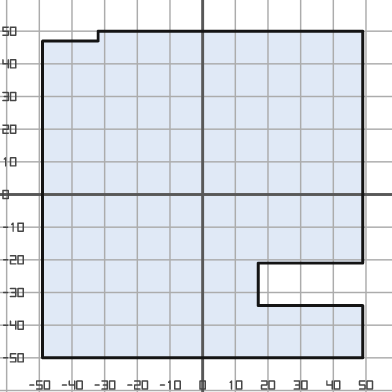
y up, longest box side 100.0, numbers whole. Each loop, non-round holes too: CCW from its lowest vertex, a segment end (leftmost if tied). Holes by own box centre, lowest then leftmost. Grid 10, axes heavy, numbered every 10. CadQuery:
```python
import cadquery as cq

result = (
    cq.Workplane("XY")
    .moveTo(-49.0, -50.0)
    .lineTo(49.0, -50.0)
    .lineTo(49.0, -34.0)
    .lineTo(17.0, -34.0)
    .lineTo(17.0, -21.0)
    .lineTo(49.0, -21.0)
    .lineTo(49.0, 50.0)
    .lineTo(-32.0, 50.0)
    .lineTo(-32.0, 47.0)
    .lineTo(-49.0, 47.0)
    .close()
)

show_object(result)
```